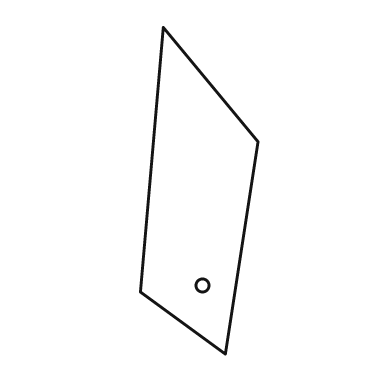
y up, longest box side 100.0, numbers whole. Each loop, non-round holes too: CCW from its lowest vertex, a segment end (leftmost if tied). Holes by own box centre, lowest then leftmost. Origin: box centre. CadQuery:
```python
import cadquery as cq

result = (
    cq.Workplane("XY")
    .moveTo(8.0, -50.0)
    .lineTo(18.0, 15.0)
    .lineTo(-11.0, 50.0)
    .lineTo(-18.0, -31.0)
    .close()
    .moveTo(1.0, -29.0)
    .circle(2.0)
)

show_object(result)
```